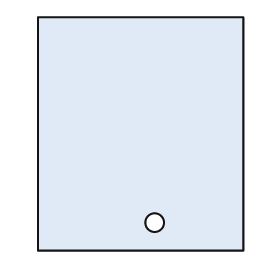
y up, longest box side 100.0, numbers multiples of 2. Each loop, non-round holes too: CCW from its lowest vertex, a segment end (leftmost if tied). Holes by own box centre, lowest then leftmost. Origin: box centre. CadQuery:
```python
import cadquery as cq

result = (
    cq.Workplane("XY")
    .moveTo(-44.0, -50.0)
    .lineTo(44.0, -50.0)
    .lineTo(44.0, 50.0)
    .lineTo(-44.0, 50.0)
    .close()
    .moveTo(6.0, -38.0)
    .circle(4.0)
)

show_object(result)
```